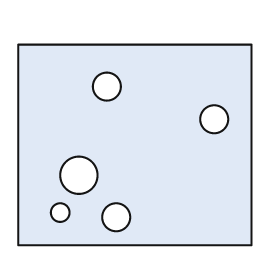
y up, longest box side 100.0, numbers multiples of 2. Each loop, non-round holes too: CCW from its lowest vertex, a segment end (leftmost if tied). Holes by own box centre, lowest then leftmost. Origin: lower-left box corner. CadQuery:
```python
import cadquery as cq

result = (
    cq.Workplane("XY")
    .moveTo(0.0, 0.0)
    .lineTo(100.0, 0.0)
    .lineTo(100.0, 86.0)
    .lineTo(0.0, 86.0)
    .close()
    .moveTo(42.0, 12.0)
    .circle(6.0)
    .moveTo(18.0, 14.0)
    .circle(4.0)
    .moveTo(26.0, 30.0)
    .circle(8.0)
    .moveTo(84.0, 54.0)
    .circle(6.0)
    .moveTo(38.0, 68.0)
    .circle(6.0)
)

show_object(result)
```